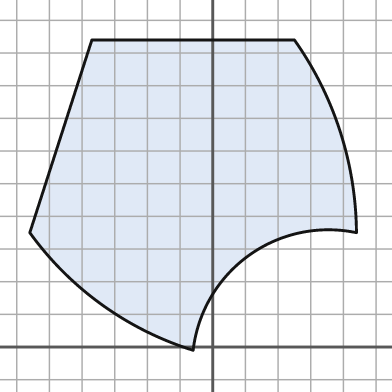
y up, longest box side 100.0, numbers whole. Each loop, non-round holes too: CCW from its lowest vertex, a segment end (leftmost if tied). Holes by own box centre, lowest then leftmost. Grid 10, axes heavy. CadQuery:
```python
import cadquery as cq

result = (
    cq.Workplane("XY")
    .moveTo(-6.0, -1.0)
    .threePointArc((11.0, 28.0), (44.0, 35.0))
    .threePointArc((39.0, 66.0), (25.0, 94.0))
    .lineTo(-37.0, 94.0)
    .lineTo(-56.0, 35.0)
    .threePointArc((-34.0, 13.0), (-6.0, -1.0))
    .close()
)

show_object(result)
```